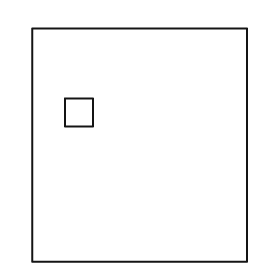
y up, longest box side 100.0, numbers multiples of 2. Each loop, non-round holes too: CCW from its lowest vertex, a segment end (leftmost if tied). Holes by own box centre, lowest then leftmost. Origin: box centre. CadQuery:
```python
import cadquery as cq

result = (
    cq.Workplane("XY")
    .moveTo(-46.0, -50.0)
    .lineTo(46.0, -50.0)
    .lineTo(46.0, 50.0)
    .lineTo(-46.0, 50.0)
    .close()
    .moveTo(-32.0, 8.0)
    .lineTo(-20.0, 8.0)
    .lineTo(-20.0, 20.0)
    .lineTo(-32.0, 20.0)
    .close()
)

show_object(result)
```